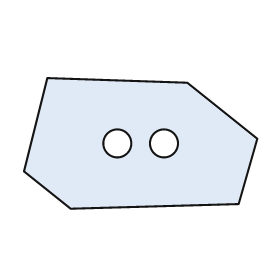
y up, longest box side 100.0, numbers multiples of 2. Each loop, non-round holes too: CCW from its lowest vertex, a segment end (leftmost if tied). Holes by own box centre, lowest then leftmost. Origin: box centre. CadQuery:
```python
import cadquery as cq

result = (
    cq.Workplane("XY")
    .moveTo(-30.0, -28.0)
    .lineTo(42.0, -26.0)
    .lineTo(50.0, 2.0)
    .lineTo(20.0, 26.0)
    .lineTo(-40.0, 28.0)
    .lineTo(-50.0, -12.0)
    .close()
    .moveTo(-10.0, 0.0)
    .circle(6.0)
    .moveTo(10.0, 0.0)
    .circle(6.0)
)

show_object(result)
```